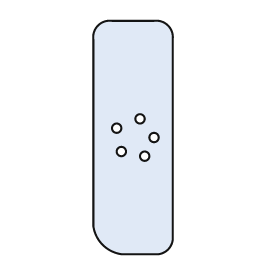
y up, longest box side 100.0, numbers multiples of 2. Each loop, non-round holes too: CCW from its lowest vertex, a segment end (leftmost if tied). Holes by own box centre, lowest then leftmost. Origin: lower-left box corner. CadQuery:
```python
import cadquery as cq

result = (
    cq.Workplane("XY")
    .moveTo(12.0, 0.0)
    .lineTo(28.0, 0.0)
    .threePointArc((32.0, 2.0), (34.0, 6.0))
    .lineTo(34.0, 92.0)
    .threePointArc((32.0, 98.0), (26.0, 100.0))
    .lineTo(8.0, 100.0)
    .threePointArc((2.0, 98.0), (0.0, 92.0))
    .lineTo(0.0, 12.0)
    .threePointArc((4.0, 4.0), (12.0, 0.0))
    .close()
    .moveTo(22.0, 42.0)
    .circle(2.0)
    .moveTo(12.0, 44.0)
    .circle(2.0)
    .moveTo(26.0, 50.0)
    .circle(2.0)
    .moveTo(10.0, 54.0)
    .circle(2.0)
    .moveTo(20.0, 58.0)
    .circle(2.0)
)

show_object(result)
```